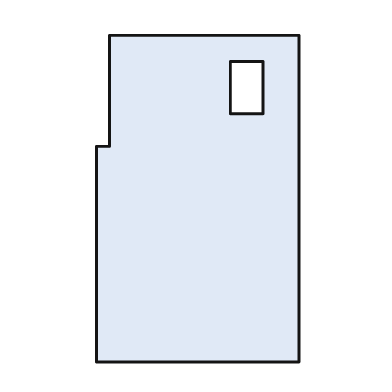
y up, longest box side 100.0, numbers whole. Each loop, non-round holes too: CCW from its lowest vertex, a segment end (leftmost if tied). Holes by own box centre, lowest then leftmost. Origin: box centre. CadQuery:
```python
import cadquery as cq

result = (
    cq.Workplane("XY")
    .moveTo(-31.0, -50.0)
    .lineTo(31.0, -50.0)
    .lineTo(31.0, 50.0)
    .lineTo(-27.0, 50.0)
    .lineTo(-27.0, 16.0)
    .lineTo(-31.0, 16.0)
    .close()
    .moveTo(10.0, 26.0)
    .lineTo(20.0, 26.0)
    .lineTo(20.0, 42.0)
    .lineTo(10.0, 42.0)
    .close()
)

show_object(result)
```